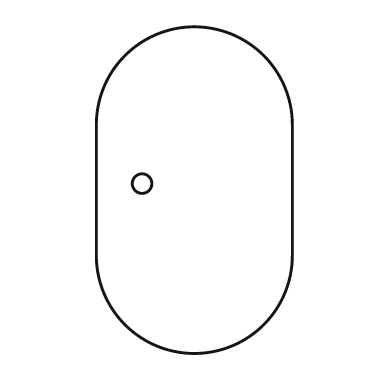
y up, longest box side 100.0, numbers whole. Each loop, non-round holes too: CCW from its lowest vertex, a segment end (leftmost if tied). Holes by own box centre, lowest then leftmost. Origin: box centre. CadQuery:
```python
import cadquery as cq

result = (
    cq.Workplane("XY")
    .moveTo(-30.0, -20.0)
    .threePointArc((0.0, -50.0), (30.0, -20.0))
    .lineTo(30.0, 20.0)
    .threePointArc((0.0, 50.0), (-30.0, 20.0))
    .close()
    .moveTo(-16.0, 2.0)
    .circle(3.0)
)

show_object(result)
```